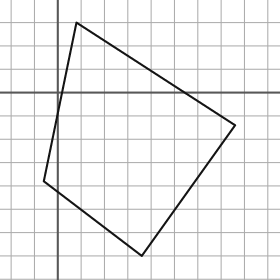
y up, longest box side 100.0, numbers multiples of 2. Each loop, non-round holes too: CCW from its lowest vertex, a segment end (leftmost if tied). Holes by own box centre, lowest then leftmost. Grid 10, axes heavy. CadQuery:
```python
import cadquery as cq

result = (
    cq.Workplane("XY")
    .moveTo(36.0, -70.0)
    .lineTo(76.0, -14.0)
    .lineTo(8.0, 30.0)
    .lineTo(-6.0, -38.0)
    .close()
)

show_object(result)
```